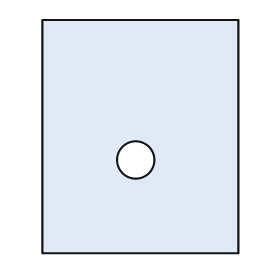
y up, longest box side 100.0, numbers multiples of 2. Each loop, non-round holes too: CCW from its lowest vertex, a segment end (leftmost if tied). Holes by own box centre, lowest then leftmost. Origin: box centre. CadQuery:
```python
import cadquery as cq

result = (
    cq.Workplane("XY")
    .moveTo(-42.0, -50.0)
    .lineTo(42.0, -50.0)
    .lineTo(42.0, 50.0)
    .lineTo(-42.0, 50.0)
    .close()
    .moveTo(-2.0, -10.0)
    .circle(8.0)
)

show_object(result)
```